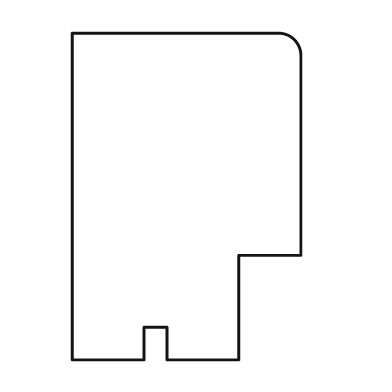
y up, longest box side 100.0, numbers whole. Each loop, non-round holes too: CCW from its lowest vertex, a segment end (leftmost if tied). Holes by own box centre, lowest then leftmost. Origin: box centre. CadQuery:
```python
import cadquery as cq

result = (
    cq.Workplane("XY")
    .moveTo(-35.0, -50.0)
    .lineTo(-13.0, -50.0)
    .lineTo(-13.0, -40.0)
    .lineTo(-6.0, -40.0)
    .lineTo(-6.0, -50.0)
    .lineTo(16.0, -50.0)
    .lineTo(16.0, -18.0)
    .lineTo(35.0, -18.0)
    .lineTo(35.0, 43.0)
    .threePointArc((33.0, 48.0), (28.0, 50.0))
    .lineTo(-35.0, 50.0)
    .close()
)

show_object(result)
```